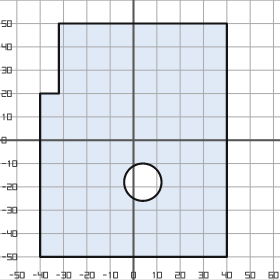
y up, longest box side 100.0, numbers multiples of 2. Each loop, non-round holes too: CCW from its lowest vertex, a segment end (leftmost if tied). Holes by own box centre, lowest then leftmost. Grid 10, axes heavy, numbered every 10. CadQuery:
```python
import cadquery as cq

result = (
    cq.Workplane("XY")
    .moveTo(-40.0, -50.0)
    .lineTo(40.0, -50.0)
    .lineTo(40.0, 50.0)
    .lineTo(-32.0, 50.0)
    .lineTo(-32.0, 20.0)
    .lineTo(-40.0, 20.0)
    .close()
    .moveTo(4.0, -18.0)
    .circle(8.0)
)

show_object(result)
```